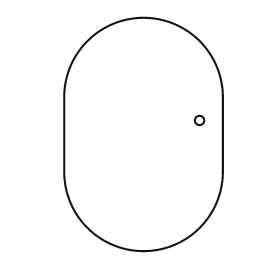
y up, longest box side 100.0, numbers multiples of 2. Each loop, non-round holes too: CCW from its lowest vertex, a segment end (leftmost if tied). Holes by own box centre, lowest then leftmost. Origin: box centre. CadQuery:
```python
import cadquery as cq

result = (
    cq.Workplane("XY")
    .moveTo(-34.0, -16.0)
    .threePointArc((0.0, -50.0), (34.0, -16.0))
    .lineTo(34.0, 16.0)
    .threePointArc((0.0, 50.0), (-34.0, 16.0))
    .close()
    .moveTo(24.0, 6.0)
    .circle(2.0)
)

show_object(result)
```